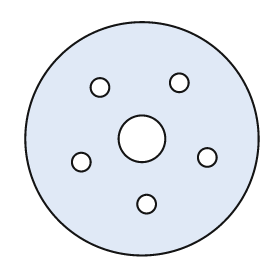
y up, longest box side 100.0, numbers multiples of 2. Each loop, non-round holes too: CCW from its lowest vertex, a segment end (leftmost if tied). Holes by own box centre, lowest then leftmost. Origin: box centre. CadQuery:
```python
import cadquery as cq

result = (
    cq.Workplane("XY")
    .moveTo(0.0, 0.0)
    .circle(50.0)
    .moveTo(2.0, -28.0)
    .circle(4.0)
    .moveTo(-26.0, -10.0)
    .circle(4.0)
    .moveTo(28.0, -8.0)
    .circle(4.0)
    .moveTo(0.0, 0.0)
    .circle(10.0)
    .moveTo(-18.0, 22.0)
    .circle(4.0)
    .moveTo(16.0, 24.0)
    .circle(4.0)
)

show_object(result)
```